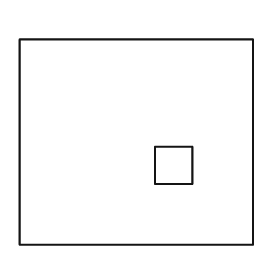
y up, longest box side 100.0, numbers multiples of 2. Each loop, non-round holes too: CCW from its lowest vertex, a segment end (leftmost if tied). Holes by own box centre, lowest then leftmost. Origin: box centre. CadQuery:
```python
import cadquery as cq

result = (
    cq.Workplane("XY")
    .moveTo(-50.0, -44.0)
    .lineTo(50.0, -44.0)
    .lineTo(50.0, 44.0)
    .lineTo(-50.0, 44.0)
    .close()
    .moveTo(8.0, -18.0)
    .lineTo(24.0, -18.0)
    .lineTo(24.0, -2.0)
    .lineTo(8.0, -2.0)
    .close()
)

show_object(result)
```